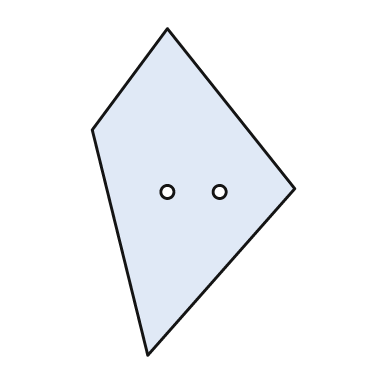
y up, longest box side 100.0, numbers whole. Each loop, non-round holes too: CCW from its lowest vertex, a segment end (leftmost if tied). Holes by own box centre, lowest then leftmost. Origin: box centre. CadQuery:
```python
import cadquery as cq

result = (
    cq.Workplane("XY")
    .moveTo(-14.0, -50.0)
    .lineTo(31.0, 1.0)
    .lineTo(-8.0, 50.0)
    .lineTo(-31.0, 19.0)
    .close()
    .moveTo(-8.0, 0.0)
    .circle(2.0)
    .moveTo(8.0, 0.0)
    .circle(2.0)
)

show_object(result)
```